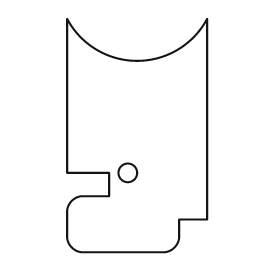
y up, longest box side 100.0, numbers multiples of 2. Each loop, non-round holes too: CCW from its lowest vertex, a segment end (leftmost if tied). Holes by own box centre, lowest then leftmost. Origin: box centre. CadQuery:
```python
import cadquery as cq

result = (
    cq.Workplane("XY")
    .moveTo(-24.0, -50.0)
    .lineTo(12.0, -50.0)
    .threePointArc((16.0, -48.0), (18.0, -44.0))
    .lineTo(18.0, -36.0)
    .lineTo(30.0, -36.0)
    .lineTo(30.0, 50.0)
    .threePointArc((0.0, 32.0), (-30.0, 50.0))
    .lineTo(-30.0, -16.0)
    .lineTo(-12.0, -16.0)
    .lineTo(-12.0, -26.0)
    .lineTo(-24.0, -26.0)
    .threePointArc((-28.0, -28.0), (-30.0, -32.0))
    .lineTo(-30.0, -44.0)
    .threePointArc((-28.0, -48.0), (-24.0, -50.0))
    .close()
    .moveTo(-4.0, -16.0)
    .circle(4.0)
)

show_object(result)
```